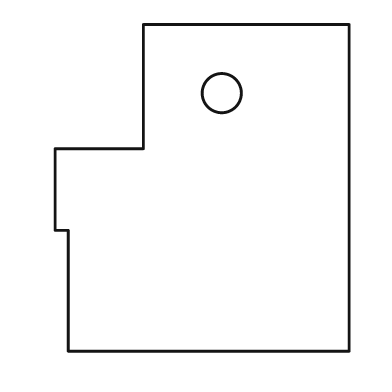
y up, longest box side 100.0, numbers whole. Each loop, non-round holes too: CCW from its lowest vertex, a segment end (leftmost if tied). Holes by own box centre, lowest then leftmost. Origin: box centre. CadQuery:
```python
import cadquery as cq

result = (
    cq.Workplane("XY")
    .moveTo(-41.0, -50.0)
    .lineTo(45.0, -50.0)
    .lineTo(45.0, 50.0)
    .lineTo(-18.0, 50.0)
    .lineTo(-18.0, 12.0)
    .lineTo(-45.0, 12.0)
    .lineTo(-45.0, -13.0)
    .lineTo(-41.0, -13.0)
    .close()
    .moveTo(6.0, 29.0)
    .circle(6.0)
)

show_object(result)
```